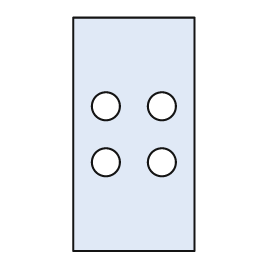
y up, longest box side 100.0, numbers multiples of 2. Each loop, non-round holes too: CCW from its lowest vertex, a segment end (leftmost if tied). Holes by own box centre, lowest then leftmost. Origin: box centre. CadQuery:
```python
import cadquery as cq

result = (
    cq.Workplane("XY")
    .moveTo(-26.0, -50.0)
    .lineTo(26.0, -50.0)
    .lineTo(26.0, 50.0)
    .lineTo(-26.0, 50.0)
    .close()
    .moveTo(-12.0, -12.0)
    .circle(6.0)
    .moveTo(12.0, -12.0)
    .circle(6.0)
    .moveTo(-12.0, 12.0)
    .circle(6.0)
    .moveTo(12.0, 12.0)
    .circle(6.0)
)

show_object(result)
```